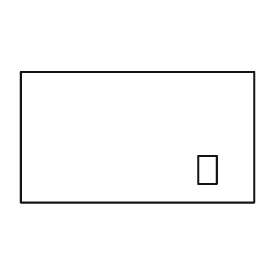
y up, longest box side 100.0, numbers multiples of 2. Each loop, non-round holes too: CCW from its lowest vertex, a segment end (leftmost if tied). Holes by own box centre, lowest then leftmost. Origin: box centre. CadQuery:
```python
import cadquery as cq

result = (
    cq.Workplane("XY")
    .moveTo(-50.0, -28.0)
    .lineTo(50.0, -28.0)
    .lineTo(50.0, 28.0)
    .lineTo(-50.0, 28.0)
    .close()
    .moveTo(26.0, -20.0)
    .lineTo(34.0, -20.0)
    .lineTo(34.0, -8.0)
    .lineTo(26.0, -8.0)
    .close()
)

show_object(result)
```